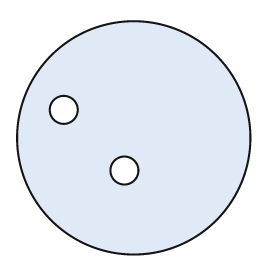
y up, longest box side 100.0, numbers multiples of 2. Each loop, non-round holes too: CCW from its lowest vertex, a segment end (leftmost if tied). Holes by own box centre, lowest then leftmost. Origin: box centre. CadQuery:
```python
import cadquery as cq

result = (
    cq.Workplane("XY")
    .moveTo(0.0, 0.0)
    .circle(50.0)
    .moveTo(-4.0, -14.0)
    .circle(6.0)
    .moveTo(-30.0, 12.0)
    .circle(6.0)
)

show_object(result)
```